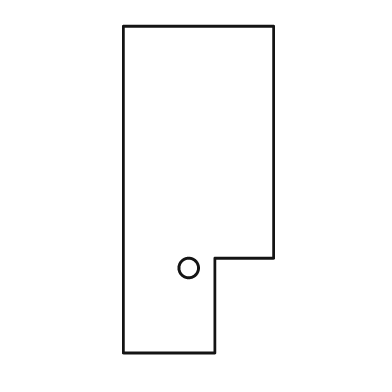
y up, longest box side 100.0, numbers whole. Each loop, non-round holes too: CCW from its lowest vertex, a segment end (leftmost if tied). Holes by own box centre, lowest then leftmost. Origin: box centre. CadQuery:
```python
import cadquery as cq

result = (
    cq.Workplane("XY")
    .moveTo(-23.0, -50.0)
    .lineTo(5.0, -50.0)
    .lineTo(5.0, -21.0)
    .lineTo(23.0, -21.0)
    .lineTo(23.0, 50.0)
    .lineTo(-23.0, 50.0)
    .close()
    .moveTo(-3.0, -24.0)
    .circle(3.0)
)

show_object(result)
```